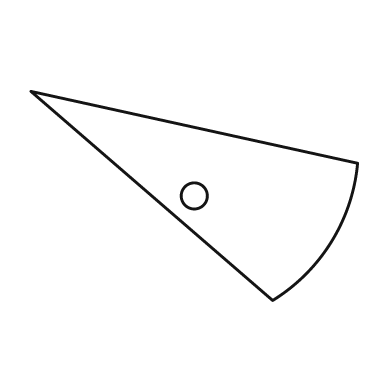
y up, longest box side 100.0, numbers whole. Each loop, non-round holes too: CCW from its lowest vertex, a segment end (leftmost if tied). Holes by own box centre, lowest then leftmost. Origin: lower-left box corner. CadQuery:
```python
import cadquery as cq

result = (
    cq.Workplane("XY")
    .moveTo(74.0, 0.0)
    .threePointArc((92.0, 18.0), (100.0, 42.0))
    .lineTo(0.0, 64.0)
    .close()
    .moveTo(50.0, 32.0)
    .circle(4.0)
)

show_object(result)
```